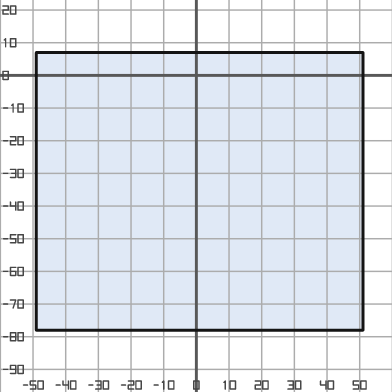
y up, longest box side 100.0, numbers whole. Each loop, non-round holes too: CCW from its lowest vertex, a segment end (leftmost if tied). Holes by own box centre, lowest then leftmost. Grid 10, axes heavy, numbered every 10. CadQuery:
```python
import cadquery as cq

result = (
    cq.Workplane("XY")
    .moveTo(-49.0, -78.0)
    .lineTo(51.0, -78.0)
    .lineTo(51.0, 7.0)
    .lineTo(-49.0, 7.0)
    .close()
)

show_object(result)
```